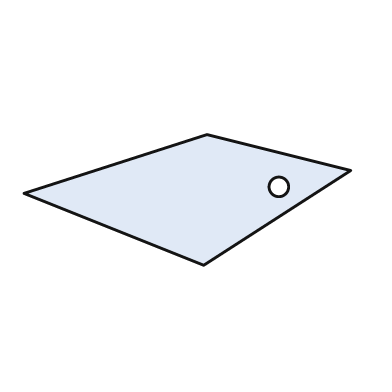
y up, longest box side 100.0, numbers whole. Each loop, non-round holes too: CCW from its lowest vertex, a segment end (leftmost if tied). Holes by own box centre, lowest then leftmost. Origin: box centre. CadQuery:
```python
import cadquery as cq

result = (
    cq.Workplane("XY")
    .moveTo(5.0, -20.0)
    .lineTo(50.0, 9.0)
    .lineTo(6.0, 20.0)
    .lineTo(-50.0, 2.0)
    .close()
    .moveTo(28.0, 4.0)
    .circle(3.0)
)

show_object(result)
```